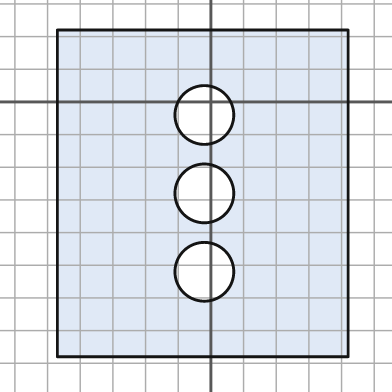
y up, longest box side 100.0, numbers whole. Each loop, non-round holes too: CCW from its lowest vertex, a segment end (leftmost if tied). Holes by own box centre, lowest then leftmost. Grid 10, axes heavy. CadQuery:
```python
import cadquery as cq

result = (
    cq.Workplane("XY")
    .moveTo(-47.0, -78.0)
    .lineTo(42.0, -78.0)
    .lineTo(42.0, 22.0)
    .lineTo(-47.0, 22.0)
    .close()
    .moveTo(-2.0, -52.0)
    .circle(9.0)
    .moveTo(-2.0, -28.0)
    .circle(9.0)
    .moveTo(-2.0, -4.0)
    .circle(9.0)
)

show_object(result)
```